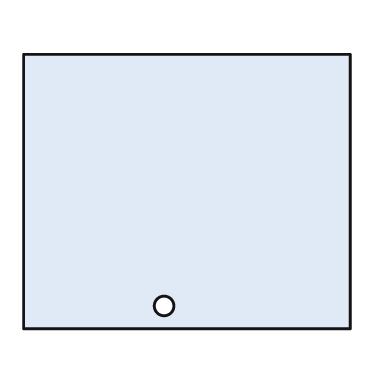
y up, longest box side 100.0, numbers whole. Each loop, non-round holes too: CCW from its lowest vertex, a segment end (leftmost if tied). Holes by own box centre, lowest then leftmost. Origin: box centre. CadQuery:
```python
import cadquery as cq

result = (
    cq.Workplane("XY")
    .moveTo(-50.0, -42.0)
    .lineTo(50.0, -42.0)
    .lineTo(50.0, 42.0)
    .lineTo(-50.0, 42.0)
    .close()
    .moveTo(-7.0, -35.0)
    .circle(3.0)
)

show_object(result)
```